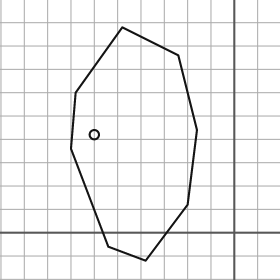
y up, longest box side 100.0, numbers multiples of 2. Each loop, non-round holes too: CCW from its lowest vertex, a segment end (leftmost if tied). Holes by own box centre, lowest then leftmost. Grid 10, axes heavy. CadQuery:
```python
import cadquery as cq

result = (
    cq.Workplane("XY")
    .moveTo(-38.0, -12.0)
    .lineTo(-20.0, 12.0)
    .lineTo(-16.0, 44.0)
    .lineTo(-24.0, 76.0)
    .lineTo(-48.0, 88.0)
    .lineTo(-68.0, 60.0)
    .lineTo(-70.0, 36.0)
    .lineTo(-54.0, -6.0)
    .close()
    .moveTo(-60.0, 42.0)
    .circle(2.0)
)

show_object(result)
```